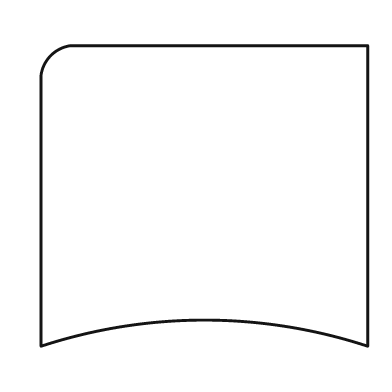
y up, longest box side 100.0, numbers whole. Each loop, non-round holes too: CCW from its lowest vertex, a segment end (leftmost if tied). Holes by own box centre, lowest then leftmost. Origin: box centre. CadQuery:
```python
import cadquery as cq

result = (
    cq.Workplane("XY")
    .moveTo(-50.0, -46.0)
    .threePointArc((0.0, -38.0), (50.0, -46.0))
    .lineTo(50.0, 46.0)
    .lineTo(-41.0, 46.0)
    .threePointArc((-47.0, 43.0), (-50.0, 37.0))
    .close()
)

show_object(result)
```